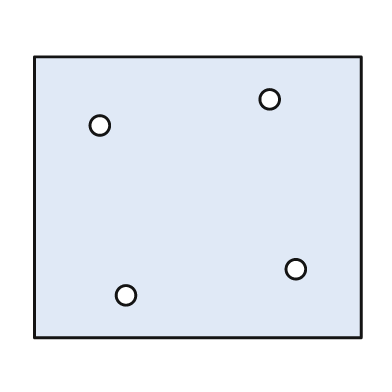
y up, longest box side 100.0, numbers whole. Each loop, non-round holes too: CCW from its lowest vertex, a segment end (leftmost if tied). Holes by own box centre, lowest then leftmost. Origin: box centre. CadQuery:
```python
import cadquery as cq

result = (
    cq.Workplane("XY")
    .moveTo(-50.0, -43.0)
    .lineTo(50.0, -43.0)
    .lineTo(50.0, 43.0)
    .lineTo(-50.0, 43.0)
    .close()
    .moveTo(-22.0, -30.0)
    .circle(3.0)
    .moveTo(30.0, -22.0)
    .circle(3.0)
    .moveTo(-30.0, 22.0)
    .circle(3.0)
    .moveTo(22.0, 30.0)
    .circle(3.0)
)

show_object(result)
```